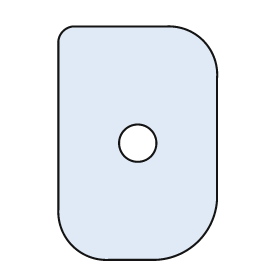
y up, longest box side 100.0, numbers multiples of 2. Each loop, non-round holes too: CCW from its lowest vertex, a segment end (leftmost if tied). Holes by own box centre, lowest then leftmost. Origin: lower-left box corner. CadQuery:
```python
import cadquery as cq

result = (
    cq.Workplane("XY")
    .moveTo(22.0, 0.0)
    .lineTo(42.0, 0.0)
    .threePointArc((60.0, 8.0), (68.0, 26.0))
    .lineTo(68.0, 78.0)
    .threePointArc((62.0, 94.0), (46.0, 100.0))
    .lineTo(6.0, 100.0)
    .threePointArc((2.0, 98.0), (0.0, 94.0))
    .lineTo(0.0, 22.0)
    .threePointArc((6.0, 6.0), (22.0, 0.0))
    .close()
    .moveTo(34.0, 50.0)
    .circle(8.0)
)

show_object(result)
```